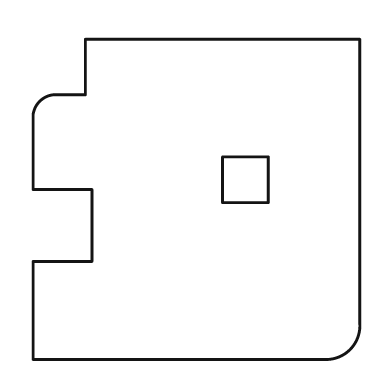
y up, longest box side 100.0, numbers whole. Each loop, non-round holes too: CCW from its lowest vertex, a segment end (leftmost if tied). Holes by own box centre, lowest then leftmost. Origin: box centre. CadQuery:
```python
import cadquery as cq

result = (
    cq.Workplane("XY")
    .moveTo(-50.0, -49.0)
    .lineTo(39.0, -49.0)
    .threePointArc((47.0, -46.0), (50.0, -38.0))
    .lineTo(50.0, 49.0)
    .lineTo(-34.0, 49.0)
    .lineTo(-34.0, 32.0)
    .lineTo(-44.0, 32.0)
    .threePointArc((-48.0, 30.0), (-50.0, 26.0))
    .lineTo(-50.0, 3.0)
    .lineTo(-32.0, 3.0)
    .lineTo(-32.0, -19.0)
    .lineTo(-50.0, -19.0)
    .close()
    .moveTo(8.0, -1.0)
    .lineTo(22.0, -1.0)
    .lineTo(22.0, 13.0)
    .lineTo(8.0, 13.0)
    .close()
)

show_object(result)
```